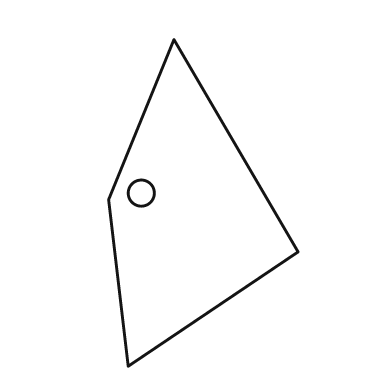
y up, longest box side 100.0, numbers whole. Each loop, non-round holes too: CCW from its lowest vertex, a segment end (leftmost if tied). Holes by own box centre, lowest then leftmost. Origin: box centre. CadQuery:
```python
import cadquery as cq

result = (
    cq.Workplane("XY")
    .moveTo(-23.0, -50.0)
    .lineTo(29.0, -15.0)
    .lineTo(-9.0, 50.0)
    .lineTo(-29.0, 1.0)
    .close()
    .moveTo(-19.0, 3.0)
    .circle(4.0)
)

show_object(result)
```